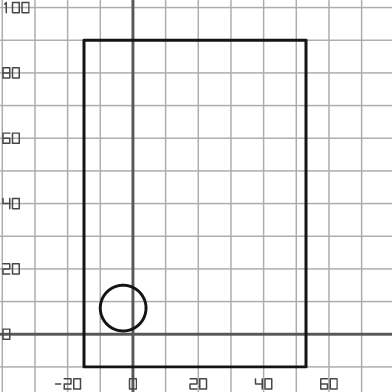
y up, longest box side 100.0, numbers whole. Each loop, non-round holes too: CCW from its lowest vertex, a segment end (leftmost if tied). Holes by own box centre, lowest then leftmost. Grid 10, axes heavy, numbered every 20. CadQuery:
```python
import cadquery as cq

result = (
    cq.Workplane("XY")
    .moveTo(-15.0, -10.0)
    .lineTo(53.0, -10.0)
    .lineTo(53.0, 90.0)
    .lineTo(-15.0, 90.0)
    .close()
    .moveTo(-3.0, 8.0)
    .circle(7.0)
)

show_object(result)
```